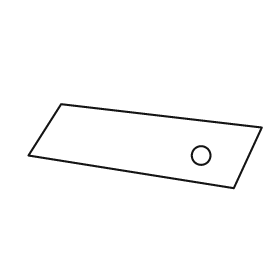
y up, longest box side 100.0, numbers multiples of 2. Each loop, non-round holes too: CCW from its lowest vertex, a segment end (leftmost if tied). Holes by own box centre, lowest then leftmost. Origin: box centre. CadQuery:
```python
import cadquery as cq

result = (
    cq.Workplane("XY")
    .moveTo(38.0, -18.0)
    .lineTo(50.0, 8.0)
    .lineTo(-36.0, 18.0)
    .lineTo(-50.0, -4.0)
    .close()
    .moveTo(24.0, -4.0)
    .circle(4.0)
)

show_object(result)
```